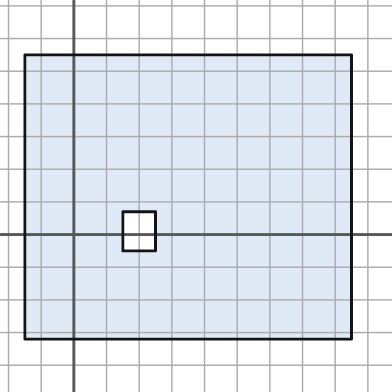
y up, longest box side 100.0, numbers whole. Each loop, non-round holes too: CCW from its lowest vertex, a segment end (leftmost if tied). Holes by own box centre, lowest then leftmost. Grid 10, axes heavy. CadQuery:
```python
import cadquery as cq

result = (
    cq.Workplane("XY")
    .moveTo(-15.0, -32.0)
    .lineTo(85.0, -32.0)
    .lineTo(85.0, 55.0)
    .lineTo(-15.0, 55.0)
    .close()
    .moveTo(15.0, -5.0)
    .lineTo(25.0, -5.0)
    .lineTo(25.0, 7.0)
    .lineTo(15.0, 7.0)
    .close()
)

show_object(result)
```